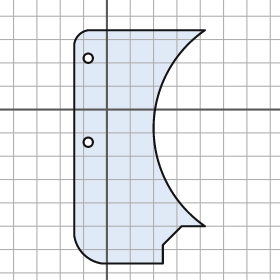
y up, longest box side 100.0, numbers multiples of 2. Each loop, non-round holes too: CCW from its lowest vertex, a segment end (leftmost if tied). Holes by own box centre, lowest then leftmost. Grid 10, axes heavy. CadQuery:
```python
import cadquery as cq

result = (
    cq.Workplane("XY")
    .moveTo(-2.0, -66.0)
    .lineTo(24.0, -66.0)
    .lineTo(24.0, -58.0)
    .lineTo(32.0, -50.0)
    .lineTo(42.0, -50.0)
    .threePointArc((20.0, -8.0), (42.0, 34.0))
    .lineTo(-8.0, 34.0)
    .threePointArc((-12.0, 32.0), (-14.0, 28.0))
    .lineTo(-14.0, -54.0)
    .threePointArc((-10.0, -62.0), (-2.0, -66.0))
    .close()
    .moveTo(-8.0, -14.0)
    .circle(2.0)
    .moveTo(-8.0, 22.0)
    .circle(2.0)
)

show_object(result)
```